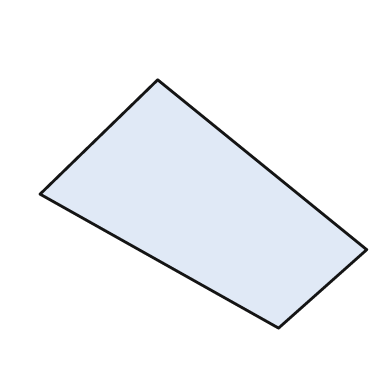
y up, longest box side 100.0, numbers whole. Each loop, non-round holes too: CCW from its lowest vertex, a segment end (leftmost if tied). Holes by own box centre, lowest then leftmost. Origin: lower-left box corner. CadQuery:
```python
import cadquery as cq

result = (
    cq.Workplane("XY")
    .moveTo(73.0, 0.0)
    .lineTo(100.0, 24.0)
    .lineTo(36.0, 76.0)
    .lineTo(0.0, 41.0)
    .close()
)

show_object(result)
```